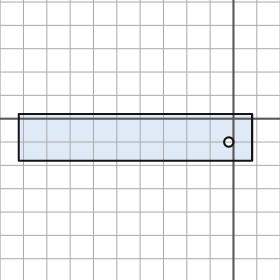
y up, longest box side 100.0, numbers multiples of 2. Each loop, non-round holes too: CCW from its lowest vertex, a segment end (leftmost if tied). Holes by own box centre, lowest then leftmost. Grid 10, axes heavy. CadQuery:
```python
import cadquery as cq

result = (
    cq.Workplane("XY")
    .moveTo(-92.0, -18.0)
    .lineTo(8.0, -18.0)
    .lineTo(8.0, 2.0)
    .lineTo(-92.0, 2.0)
    .close()
    .moveTo(-2.0, -10.0)
    .circle(2.0)
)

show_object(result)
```